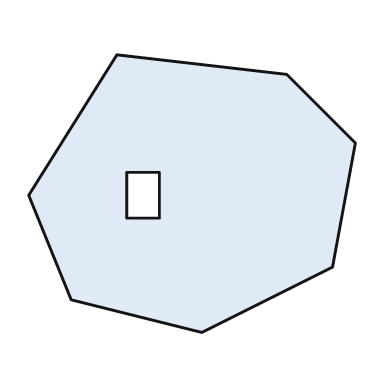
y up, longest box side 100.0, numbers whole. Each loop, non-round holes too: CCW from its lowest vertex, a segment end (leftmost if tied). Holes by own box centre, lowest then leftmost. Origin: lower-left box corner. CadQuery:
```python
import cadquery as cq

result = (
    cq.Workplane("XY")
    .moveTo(53.0, 0.0)
    .lineTo(93.0, 20.0)
    .lineTo(100.0, 58.0)
    .lineTo(79.0, 79.0)
    .lineTo(27.0, 85.0)
    .lineTo(0.0, 42.0)
    .lineTo(13.0, 10.0)
    .close()
    .moveTo(30.0, 35.0)
    .lineTo(40.0, 35.0)
    .lineTo(40.0, 49.0)
    .lineTo(30.0, 49.0)
    .close()
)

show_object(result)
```